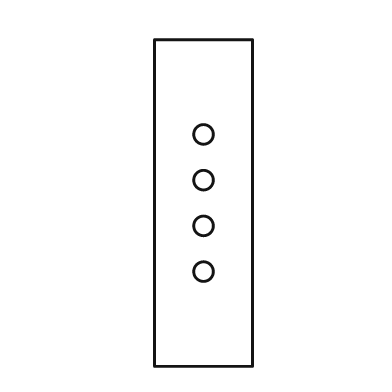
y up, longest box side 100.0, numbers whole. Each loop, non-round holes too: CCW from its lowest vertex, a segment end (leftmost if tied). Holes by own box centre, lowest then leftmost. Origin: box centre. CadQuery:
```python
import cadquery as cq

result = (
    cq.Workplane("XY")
    .moveTo(-15.0, -50.0)
    .lineTo(15.0, -50.0)
    .lineTo(15.0, 50.0)
    .lineTo(-15.0, 50.0)
    .close()
    .moveTo(0.0, -21.0)
    .circle(3.0)
    .moveTo(0.0, -7.0)
    .circle(3.0)
    .moveTo(0.0, 7.0)
    .circle(3.0)
    .moveTo(0.0, 21.0)
    .circle(3.0)
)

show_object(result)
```